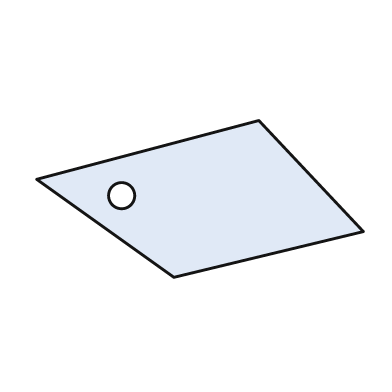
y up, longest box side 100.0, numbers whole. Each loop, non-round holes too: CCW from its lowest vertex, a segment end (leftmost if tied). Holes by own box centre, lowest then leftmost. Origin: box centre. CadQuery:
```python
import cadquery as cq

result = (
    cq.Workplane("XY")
    .moveTo(-8.0, -24.0)
    .lineTo(50.0, -10.0)
    .lineTo(18.0, 24.0)
    .lineTo(-50.0, 6.0)
    .close()
    .moveTo(-24.0, 1.0)
    .circle(4.0)
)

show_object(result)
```